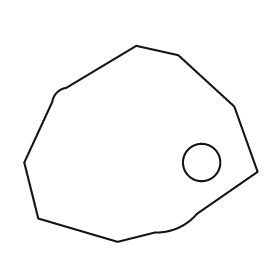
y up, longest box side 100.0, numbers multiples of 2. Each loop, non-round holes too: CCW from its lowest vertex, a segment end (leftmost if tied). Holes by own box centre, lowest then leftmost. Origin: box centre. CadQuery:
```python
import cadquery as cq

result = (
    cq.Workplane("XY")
    .moveTo(-10.0, -42.0)
    .lineTo(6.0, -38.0)
    .threePointArc((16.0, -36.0), (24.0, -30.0))
    .lineTo(50.0, -12.0)
    .lineTo(40.0, 16.0)
    .lineTo(16.0, 38.0)
    .lineTo(-2.0, 42.0)
    .lineTo(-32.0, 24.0)
    .threePointArc((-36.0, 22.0), (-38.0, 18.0))
    .lineTo(-50.0, -8.0)
    .lineTo(-44.0, -32.0)
    .close()
    .moveTo(26.0, -8.0)
    .circle(8.0)
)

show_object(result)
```